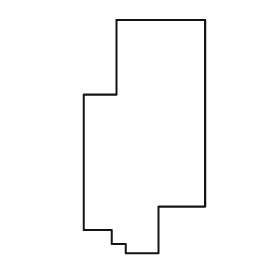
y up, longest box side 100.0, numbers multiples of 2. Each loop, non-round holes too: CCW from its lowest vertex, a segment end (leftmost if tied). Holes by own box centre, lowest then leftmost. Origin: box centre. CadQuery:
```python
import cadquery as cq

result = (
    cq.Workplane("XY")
    .moveTo(-8.0, -50.0)
    .lineTo(6.0, -50.0)
    .lineTo(6.0, -30.0)
    .lineTo(26.0, -30.0)
    .lineTo(26.0, 50.0)
    .lineTo(-12.0, 50.0)
    .lineTo(-12.0, 18.0)
    .lineTo(-26.0, 18.0)
    .lineTo(-26.0, -40.0)
    .lineTo(-14.0, -40.0)
    .lineTo(-14.0, -46.0)
    .lineTo(-8.0, -46.0)
    .close()
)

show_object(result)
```